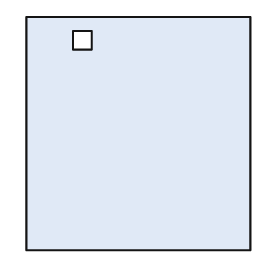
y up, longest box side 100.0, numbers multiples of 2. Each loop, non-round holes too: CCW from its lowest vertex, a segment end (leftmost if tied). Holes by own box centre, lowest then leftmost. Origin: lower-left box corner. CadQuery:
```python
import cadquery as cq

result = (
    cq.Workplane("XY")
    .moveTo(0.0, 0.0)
    .lineTo(96.0, 0.0)
    .lineTo(96.0, 100.0)
    .lineTo(0.0, 100.0)
    .close()
    .moveTo(20.0, 86.0)
    .lineTo(28.0, 86.0)
    .lineTo(28.0, 94.0)
    .lineTo(20.0, 94.0)
    .close()
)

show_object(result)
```